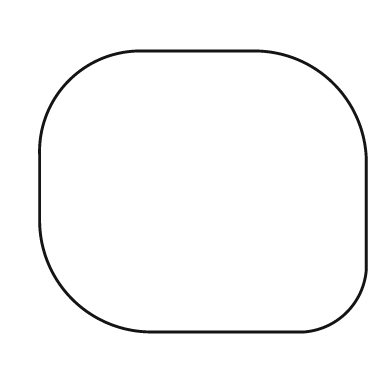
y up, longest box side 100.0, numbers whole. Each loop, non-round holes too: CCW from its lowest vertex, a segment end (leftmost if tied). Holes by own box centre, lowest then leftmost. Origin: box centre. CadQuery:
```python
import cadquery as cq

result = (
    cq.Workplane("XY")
    .moveTo(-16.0, -43.0)
    .lineTo(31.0, -43.0)
    .threePointArc((44.0, -37.0), (50.0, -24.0))
    .lineTo(50.0, 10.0)
    .threePointArc((40.0, 33.0), (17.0, 43.0))
    .lineTo(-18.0, 43.0)
    .threePointArc((-41.0, 34.0), (-50.0, 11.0))
    .lineTo(-50.0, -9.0)
    .threePointArc((-40.0, -33.0), (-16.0, -43.0))
    .close()
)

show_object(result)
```